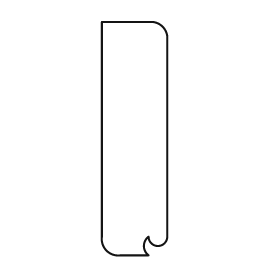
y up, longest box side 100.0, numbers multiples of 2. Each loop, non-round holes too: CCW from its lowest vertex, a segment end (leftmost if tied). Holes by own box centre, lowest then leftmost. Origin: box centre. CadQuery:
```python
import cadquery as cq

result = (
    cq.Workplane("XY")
    .moveTo(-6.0, -50.0)
    .lineTo(6.0, -50.0)
    .threePointArc((4.0, -46.0), (6.0, -42.0))
    .threePointArc((10.0, -46.0), (14.0, -42.0))
    .lineTo(14.0, 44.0)
    .threePointArc((12.0, 48.0), (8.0, 50.0))
    .lineTo(-14.0, 50.0)
    .lineTo(-14.0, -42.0)
    .threePointArc((-12.0, -48.0), (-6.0, -50.0))
    .close()
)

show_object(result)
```